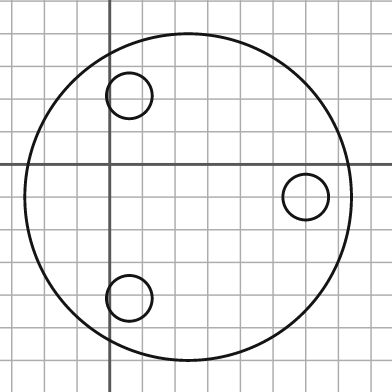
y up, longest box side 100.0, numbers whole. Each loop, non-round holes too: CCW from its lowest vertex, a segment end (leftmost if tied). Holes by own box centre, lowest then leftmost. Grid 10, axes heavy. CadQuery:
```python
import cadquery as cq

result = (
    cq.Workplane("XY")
    .moveTo(24.0, -10.0)
    .circle(50.0)
    .moveTo(6.0, -41.0)
    .circle(7.0)
    .moveTo(60.0, -10.0)
    .circle(7.0)
    .moveTo(6.0, 21.0)
    .circle(7.0)
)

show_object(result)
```